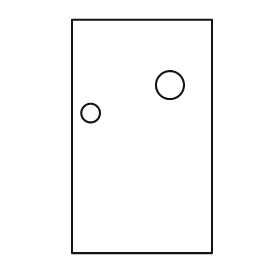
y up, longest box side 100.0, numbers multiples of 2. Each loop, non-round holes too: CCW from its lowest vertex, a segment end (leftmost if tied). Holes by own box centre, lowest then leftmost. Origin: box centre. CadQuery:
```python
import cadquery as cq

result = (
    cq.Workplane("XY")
    .moveTo(-30.0, -50.0)
    .lineTo(30.0, -50.0)
    .lineTo(30.0, 50.0)
    .lineTo(-30.0, 50.0)
    .close()
    .moveTo(-22.0, 10.0)
    .circle(4.0)
    .moveTo(12.0, 22.0)
    .circle(6.0)
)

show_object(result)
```